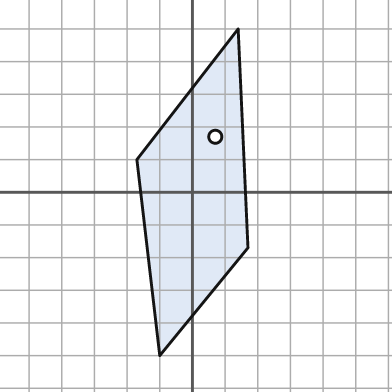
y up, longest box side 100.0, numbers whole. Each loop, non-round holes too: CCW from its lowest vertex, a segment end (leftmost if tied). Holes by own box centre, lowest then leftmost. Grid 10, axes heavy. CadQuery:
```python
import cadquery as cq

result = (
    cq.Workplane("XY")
    .moveTo(-10.0, -50.0)
    .lineTo(17.0, -17.0)
    .lineTo(14.0, 50.0)
    .lineTo(-17.0, 10.0)
    .close()
    .moveTo(7.0, 17.0)
    .circle(2.0)
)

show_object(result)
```